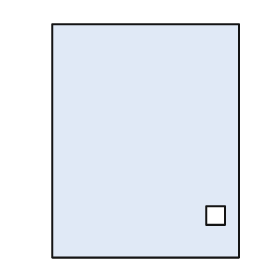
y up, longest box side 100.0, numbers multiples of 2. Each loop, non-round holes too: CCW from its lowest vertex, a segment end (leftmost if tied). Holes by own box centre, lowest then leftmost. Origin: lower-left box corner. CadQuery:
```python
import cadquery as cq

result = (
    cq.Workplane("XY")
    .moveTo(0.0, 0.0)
    .lineTo(80.0, 0.0)
    .lineTo(80.0, 100.0)
    .lineTo(0.0, 100.0)
    .close()
    .moveTo(66.0, 14.0)
    .lineTo(74.0, 14.0)
    .lineTo(74.0, 22.0)
    .lineTo(66.0, 22.0)
    .close()
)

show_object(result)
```